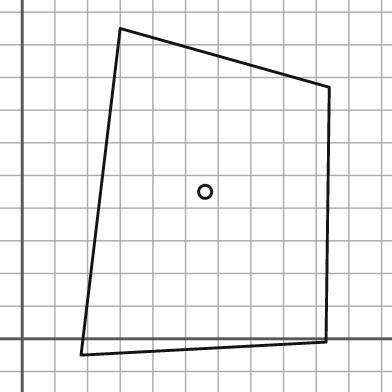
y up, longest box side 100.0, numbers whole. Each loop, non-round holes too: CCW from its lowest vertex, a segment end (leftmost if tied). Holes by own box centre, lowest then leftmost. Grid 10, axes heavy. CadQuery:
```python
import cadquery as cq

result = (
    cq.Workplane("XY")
    .moveTo(18.0, -5.0)
    .lineTo(93.0, -1.0)
    .lineTo(94.0, 77.0)
    .lineTo(30.0, 95.0)
    .close()
    .moveTo(56.0, 45.0)
    .circle(2.0)
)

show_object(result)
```